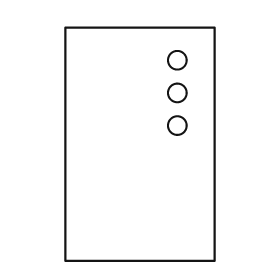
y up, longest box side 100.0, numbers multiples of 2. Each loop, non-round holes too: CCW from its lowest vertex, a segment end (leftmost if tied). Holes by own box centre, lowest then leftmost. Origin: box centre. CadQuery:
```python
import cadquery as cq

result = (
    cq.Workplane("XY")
    .moveTo(-32.0, -50.0)
    .lineTo(32.0, -50.0)
    .lineTo(32.0, 50.0)
    .lineTo(-32.0, 50.0)
    .close()
    .moveTo(16.0, 8.0)
    .circle(4.0)
    .moveTo(16.0, 22.0)
    .circle(4.0)
    .moveTo(16.0, 36.0)
    .circle(4.0)
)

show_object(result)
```